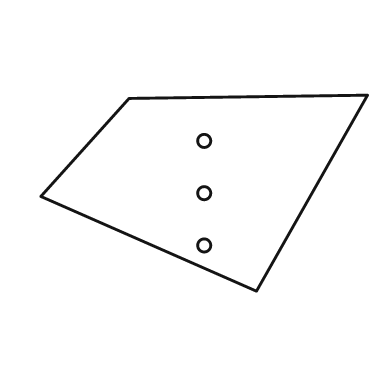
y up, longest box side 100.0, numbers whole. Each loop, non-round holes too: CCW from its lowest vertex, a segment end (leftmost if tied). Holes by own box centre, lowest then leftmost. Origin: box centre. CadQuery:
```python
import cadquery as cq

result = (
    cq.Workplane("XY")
    .moveTo(16.0, -30.0)
    .lineTo(50.0, 30.0)
    .lineTo(-23.0, 29.0)
    .lineTo(-50.0, -1.0)
    .close()
    .moveTo(0.0, -16.0)
    .circle(2.0)
    .moveTo(0.0, 0.0)
    .circle(2.0)
    .moveTo(0.0, 16.0)
    .circle(2.0)
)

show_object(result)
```